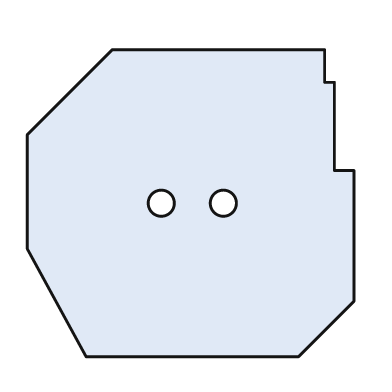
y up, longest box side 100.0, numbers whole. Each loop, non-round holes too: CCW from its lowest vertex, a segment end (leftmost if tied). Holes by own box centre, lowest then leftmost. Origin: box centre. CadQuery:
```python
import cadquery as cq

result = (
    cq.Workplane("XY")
    .moveTo(-32.0, -47.0)
    .lineTo(33.0, -47.0)
    .lineTo(50.0, -30.0)
    .lineTo(50.0, 10.0)
    .lineTo(44.0, 10.0)
    .lineTo(44.0, 37.0)
    .lineTo(41.0, 37.0)
    .lineTo(41.0, 47.0)
    .lineTo(-24.0, 47.0)
    .lineTo(-50.0, 21.0)
    .lineTo(-50.0, -14.0)
    .close()
    .moveTo(-9.0, 0.0)
    .circle(4.0)
    .moveTo(10.0, 0.0)
    .circle(4.0)
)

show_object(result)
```